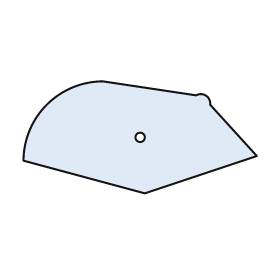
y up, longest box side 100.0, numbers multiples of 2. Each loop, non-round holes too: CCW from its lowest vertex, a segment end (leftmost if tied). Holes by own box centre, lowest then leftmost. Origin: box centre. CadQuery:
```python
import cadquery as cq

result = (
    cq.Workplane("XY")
    .moveTo(2.0, -24.0)
    .lineTo(50.0, -8.0)
    .lineTo(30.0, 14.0)
    .threePointArc((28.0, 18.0), (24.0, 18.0))
    .lineTo(-16.0, 24.0)
    .threePointArc((-40.0, 14.0), (-50.0, -10.0))
    .close()
    .moveTo(0.0, 0.0)
    .circle(2.0)
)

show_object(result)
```